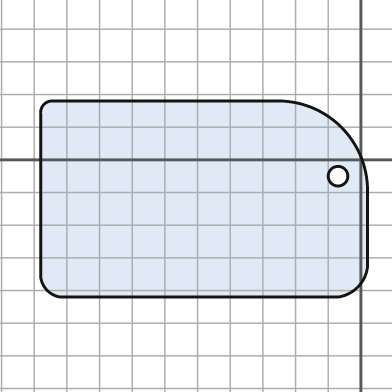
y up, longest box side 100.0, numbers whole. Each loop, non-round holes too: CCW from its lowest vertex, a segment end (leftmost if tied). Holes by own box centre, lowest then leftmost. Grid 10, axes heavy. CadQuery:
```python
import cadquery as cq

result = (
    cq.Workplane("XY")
    .moveTo(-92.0, -42.0)
    .lineTo(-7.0, -42.0)
    .threePointArc((-1.0, -39.0), (2.0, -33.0))
    .lineTo(2.0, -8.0)
    .threePointArc((-6.0, 10.0), (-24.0, 18.0))
    .lineTo(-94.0, 18.0)
    .threePointArc((-97.0, 17.0), (-98.0, 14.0))
    .lineTo(-98.0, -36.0)
    .threePointArc((-96.0, -40.0), (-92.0, -42.0))
    .close()
    .moveTo(-7.0, -5.0)
    .circle(3.0)
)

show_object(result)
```